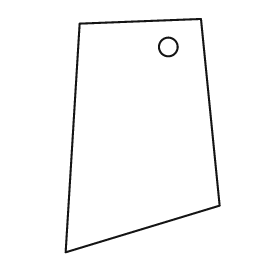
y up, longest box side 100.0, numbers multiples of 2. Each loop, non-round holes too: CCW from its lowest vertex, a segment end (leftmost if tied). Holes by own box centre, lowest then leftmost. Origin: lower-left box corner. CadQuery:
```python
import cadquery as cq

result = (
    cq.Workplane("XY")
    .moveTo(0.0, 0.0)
    .lineTo(66.0, 20.0)
    .lineTo(58.0, 100.0)
    .lineTo(6.0, 98.0)
    .close()
    .moveTo(44.0, 88.0)
    .circle(4.0)
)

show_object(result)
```